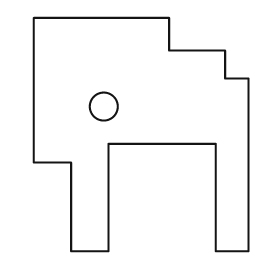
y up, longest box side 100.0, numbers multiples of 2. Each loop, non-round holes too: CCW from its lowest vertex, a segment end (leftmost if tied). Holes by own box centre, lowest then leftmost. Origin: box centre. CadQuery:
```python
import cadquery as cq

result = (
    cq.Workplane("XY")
    .moveTo(-30.0, -50.0)
    .lineTo(-14.0, -50.0)
    .lineTo(-14.0, -4.0)
    .lineTo(32.0, -4.0)
    .lineTo(32.0, -50.0)
    .lineTo(46.0, -50.0)
    .lineTo(46.0, 24.0)
    .lineTo(36.0, 24.0)
    .lineTo(36.0, 36.0)
    .lineTo(12.0, 36.0)
    .lineTo(12.0, 50.0)
    .lineTo(-46.0, 50.0)
    .lineTo(-46.0, -12.0)
    .lineTo(-30.0, -12.0)
    .close()
    .moveTo(-16.0, 12.0)
    .circle(6.0)
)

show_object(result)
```